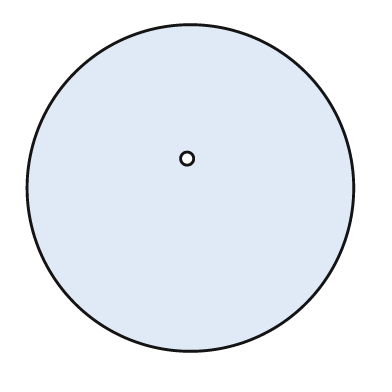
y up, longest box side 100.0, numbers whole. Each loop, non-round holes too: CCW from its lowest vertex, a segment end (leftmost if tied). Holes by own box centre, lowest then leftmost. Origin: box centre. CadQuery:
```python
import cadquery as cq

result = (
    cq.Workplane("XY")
    .moveTo(0.0, 0.0)
    .circle(50.0)
    .moveTo(-1.0, 9.0)
    .circle(2.0)
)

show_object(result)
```